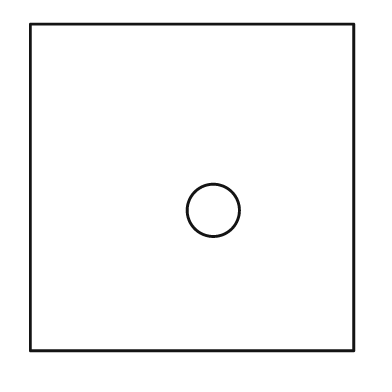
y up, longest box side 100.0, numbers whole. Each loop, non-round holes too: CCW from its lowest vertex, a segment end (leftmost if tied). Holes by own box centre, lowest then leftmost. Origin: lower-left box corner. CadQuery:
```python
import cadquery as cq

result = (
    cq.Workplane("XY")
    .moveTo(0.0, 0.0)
    .lineTo(99.0, 0.0)
    .lineTo(99.0, 100.0)
    .lineTo(0.0, 100.0)
    .close()
    .moveTo(56.0, 43.0)
    .circle(8.0)
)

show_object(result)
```